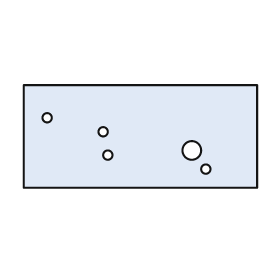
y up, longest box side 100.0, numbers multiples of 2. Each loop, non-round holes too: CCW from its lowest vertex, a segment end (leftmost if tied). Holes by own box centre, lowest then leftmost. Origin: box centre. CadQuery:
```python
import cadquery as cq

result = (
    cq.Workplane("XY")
    .moveTo(-50.0, -22.0)
    .lineTo(50.0, -22.0)
    .lineTo(50.0, 22.0)
    .lineTo(-50.0, 22.0)
    .close()
    .moveTo(28.0, -14.0)
    .circle(2.0)
    .moveTo(-14.0, -8.0)
    .circle(2.0)
    .moveTo(22.0, -6.0)
    .circle(4.0)
    .moveTo(-16.0, 2.0)
    .circle(2.0)
    .moveTo(-40.0, 8.0)
    .circle(2.0)
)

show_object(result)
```